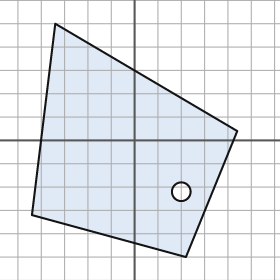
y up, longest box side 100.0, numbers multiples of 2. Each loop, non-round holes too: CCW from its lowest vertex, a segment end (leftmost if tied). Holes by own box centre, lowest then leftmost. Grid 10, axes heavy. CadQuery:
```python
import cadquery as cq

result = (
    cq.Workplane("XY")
    .moveTo(22.0, -50.0)
    .lineTo(44.0, 4.0)
    .lineTo(-34.0, 50.0)
    .lineTo(-44.0, -32.0)
    .close()
    .moveTo(20.0, -22.0)
    .circle(4.0)
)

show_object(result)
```